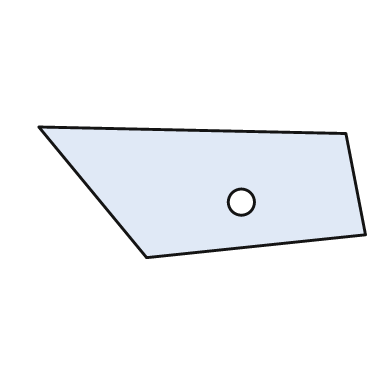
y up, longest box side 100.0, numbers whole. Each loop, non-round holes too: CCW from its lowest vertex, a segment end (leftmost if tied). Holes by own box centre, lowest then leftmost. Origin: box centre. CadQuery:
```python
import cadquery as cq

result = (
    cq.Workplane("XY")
    .moveTo(-17.0, -20.0)
    .lineTo(50.0, -13.0)
    .lineTo(44.0, 18.0)
    .lineTo(-50.0, 20.0)
    .close()
    .moveTo(12.0, -3.0)
    .circle(4.0)
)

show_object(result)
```